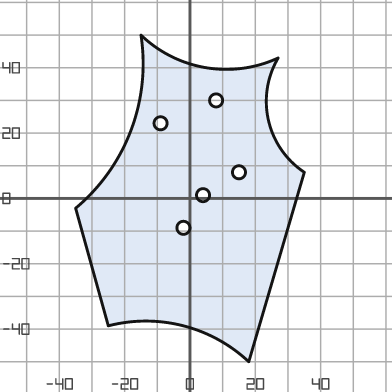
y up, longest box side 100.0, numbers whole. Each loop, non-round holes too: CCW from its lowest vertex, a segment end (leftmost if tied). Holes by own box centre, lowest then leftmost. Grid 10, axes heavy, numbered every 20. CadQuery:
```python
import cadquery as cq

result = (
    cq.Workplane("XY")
    .moveTo(18.0, -50.0)
    .lineTo(35.0, 8.0)
    .threePointArc((24.0, 24.0), (27.0, 43.0))
    .threePointArc((5.0, 40.0), (-15.0, 50.0))
    .threePointArc((-18.0, 21.0), (-35.0, -3.0))
    .lineTo(-25.0, -39.0)
    .threePointArc((-2.0, -39.0), (18.0, -50.0))
    .close()
    .moveTo(-2.0, -9.0)
    .circle(2.0)
    .moveTo(4.0, 1.0)
    .circle(2.0)
    .moveTo(15.0, 8.0)
    .circle(2.0)
    .moveTo(-9.0, 23.0)
    .circle(2.0)
    .moveTo(8.0, 30.0)
    .circle(2.0)
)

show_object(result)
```